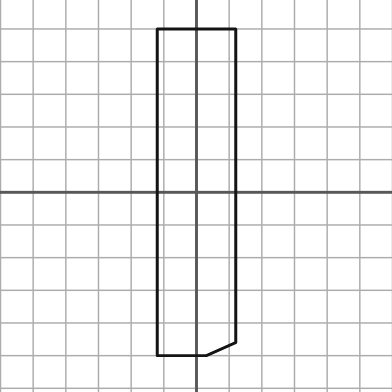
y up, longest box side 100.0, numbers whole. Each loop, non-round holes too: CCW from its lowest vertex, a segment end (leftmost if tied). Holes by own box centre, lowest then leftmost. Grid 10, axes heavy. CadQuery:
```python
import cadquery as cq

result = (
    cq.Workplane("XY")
    .moveTo(-12.0, -50.0)
    .lineTo(3.0, -50.0)
    .lineTo(12.0, -46.0)
    .lineTo(12.0, 50.0)
    .lineTo(-12.0, 50.0)
    .close()
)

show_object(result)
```